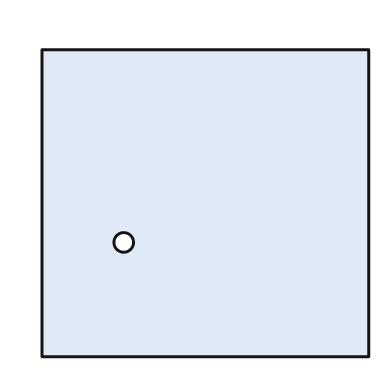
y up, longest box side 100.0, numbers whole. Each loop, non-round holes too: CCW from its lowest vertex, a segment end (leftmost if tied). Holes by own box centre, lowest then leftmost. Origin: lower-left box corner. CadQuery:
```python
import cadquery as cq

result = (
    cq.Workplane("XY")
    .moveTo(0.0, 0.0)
    .lineTo(100.0, 0.0)
    .lineTo(100.0, 94.0)
    .lineTo(0.0, 94.0)
    .close()
    .moveTo(25.0, 35.0)
    .circle(3.0)
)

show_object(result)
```